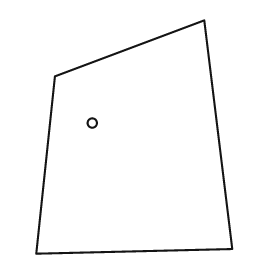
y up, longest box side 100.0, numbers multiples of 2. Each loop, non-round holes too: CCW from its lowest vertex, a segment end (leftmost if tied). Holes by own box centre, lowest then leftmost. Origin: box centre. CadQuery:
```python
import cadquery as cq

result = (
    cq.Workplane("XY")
    .moveTo(-42.0, -50.0)
    .lineTo(42.0, -48.0)
    .lineTo(30.0, 50.0)
    .lineTo(-34.0, 26.0)
    .close()
    .moveTo(-18.0, 6.0)
    .circle(2.0)
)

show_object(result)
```